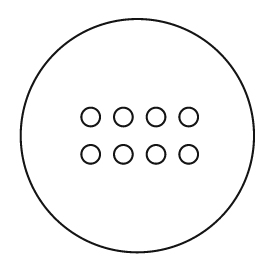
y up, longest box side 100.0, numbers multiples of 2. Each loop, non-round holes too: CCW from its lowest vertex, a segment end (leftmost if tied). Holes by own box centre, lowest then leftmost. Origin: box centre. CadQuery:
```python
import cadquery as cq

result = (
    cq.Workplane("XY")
    .moveTo(0.0, 0.0)
    .circle(50.0)
    .moveTo(-20.0, -8.0)
    .circle(4.0)
    .moveTo(-6.0, -8.0)
    .circle(4.0)
    .moveTo(8.0, -8.0)
    .circle(4.0)
    .moveTo(22.0, -8.0)
    .circle(4.0)
    .moveTo(-20.0, 8.0)
    .circle(4.0)
    .moveTo(-6.0, 8.0)
    .circle(4.0)
    .moveTo(8.0, 8.0)
    .circle(4.0)
    .moveTo(22.0, 8.0)
    .circle(4.0)
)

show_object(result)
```